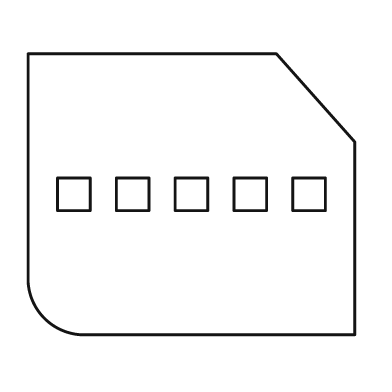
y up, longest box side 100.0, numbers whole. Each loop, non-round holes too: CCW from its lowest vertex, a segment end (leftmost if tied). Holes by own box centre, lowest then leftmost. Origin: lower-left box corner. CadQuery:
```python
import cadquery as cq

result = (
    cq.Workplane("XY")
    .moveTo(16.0, 0.0)
    .lineTo(100.0, 0.0)
    .lineTo(100.0, 59.0)
    .lineTo(76.0, 86.0)
    .lineTo(0.0, 86.0)
    .lineTo(0.0, 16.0)
    .threePointArc((5.0, 5.0), (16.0, 0.0))
    .close()
    .moveTo(9.0, 38.0)
    .lineTo(19.0, 38.0)
    .lineTo(19.0, 48.0)
    .lineTo(9.0, 48.0)
    .close()
    .moveTo(27.0, 38.0)
    .lineTo(37.0, 38.0)
    .lineTo(37.0, 48.0)
    .lineTo(27.0, 48.0)
    .close()
    .moveTo(45.0, 38.0)
    .lineTo(55.0, 38.0)
    .lineTo(55.0, 48.0)
    .lineTo(45.0, 48.0)
    .close()
    .moveTo(63.0, 38.0)
    .lineTo(73.0, 38.0)
    .lineTo(73.0, 48.0)
    .lineTo(63.0, 48.0)
    .close()
    .moveTo(81.0, 38.0)
    .lineTo(91.0, 38.0)
    .lineTo(91.0, 48.0)
    .lineTo(81.0, 48.0)
    .close()
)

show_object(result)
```